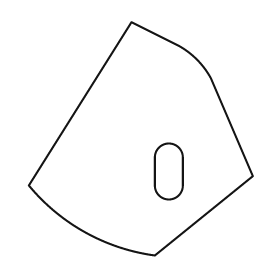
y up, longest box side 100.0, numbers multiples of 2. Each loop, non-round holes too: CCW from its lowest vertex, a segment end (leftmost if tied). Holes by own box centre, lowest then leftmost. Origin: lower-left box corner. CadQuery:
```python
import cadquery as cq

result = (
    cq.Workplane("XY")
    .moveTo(54.0, 0.0)
    .lineTo(96.0, 34.0)
    .lineTo(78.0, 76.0)
    .threePointArc((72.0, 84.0), (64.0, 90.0))
    .lineTo(44.0, 100.0)
    .lineTo(0.0, 30.0)
    .threePointArc((24.0, 10.0), (54.0, 0.0))
    .close()
    .moveTo(54.0, 30.0)
    .threePointArc((60.0, 24.0), (66.0, 30.0))
    .lineTo(66.0, 42.0)
    .threePointArc((60.0, 48.0), (54.0, 42.0))
    .close()
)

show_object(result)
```